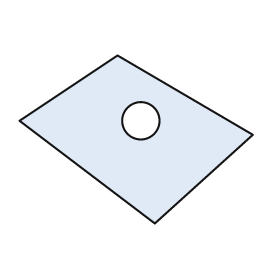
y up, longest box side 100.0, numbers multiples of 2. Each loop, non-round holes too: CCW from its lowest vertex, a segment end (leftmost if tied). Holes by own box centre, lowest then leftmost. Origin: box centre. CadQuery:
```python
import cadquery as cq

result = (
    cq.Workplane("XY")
    .moveTo(8.0, -36.0)
    .lineTo(50.0, 2.0)
    .lineTo(-8.0, 36.0)
    .lineTo(-50.0, 8.0)
    .close()
    .moveTo(2.0, 8.0)
    .circle(8.0)
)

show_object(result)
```